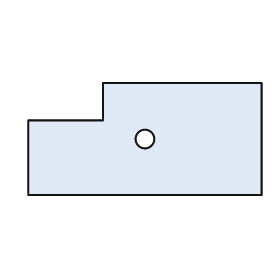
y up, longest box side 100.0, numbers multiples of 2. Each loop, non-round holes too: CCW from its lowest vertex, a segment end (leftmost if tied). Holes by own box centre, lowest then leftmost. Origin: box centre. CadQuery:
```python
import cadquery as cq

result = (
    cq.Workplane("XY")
    .moveTo(-50.0, -24.0)
    .lineTo(50.0, -24.0)
    .lineTo(50.0, 24.0)
    .lineTo(-18.0, 24.0)
    .lineTo(-18.0, 8.0)
    .lineTo(-50.0, 8.0)
    .close()
    .moveTo(0.0, 0.0)
    .circle(4.0)
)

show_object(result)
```